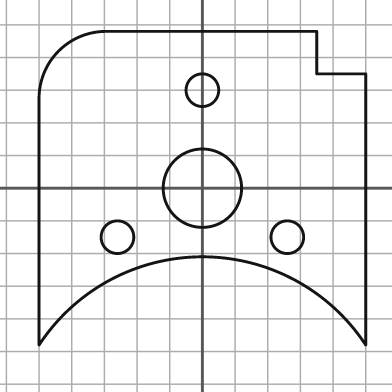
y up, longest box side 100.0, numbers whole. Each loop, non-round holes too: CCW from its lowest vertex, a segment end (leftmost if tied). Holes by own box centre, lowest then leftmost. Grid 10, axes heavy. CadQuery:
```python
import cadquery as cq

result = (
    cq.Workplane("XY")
    .moveTo(-50.0, -48.0)
    .threePointArc((0.0, -21.0), (50.0, -48.0))
    .lineTo(50.0, 35.0)
    .lineTo(35.0, 35.0)
    .lineTo(35.0, 48.0)
    .lineTo(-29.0, 48.0)
    .threePointArc((-44.0, 42.0), (-50.0, 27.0))
    .close()
    .moveTo(-26.0, -15.0)
    .circle(5.0)
    .moveTo(26.0, -15.0)
    .circle(5.0)
    .moveTo(0.0, 0.0)
    .circle(12.0)
    .moveTo(0.0, 30.0)
    .circle(5.0)
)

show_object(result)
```